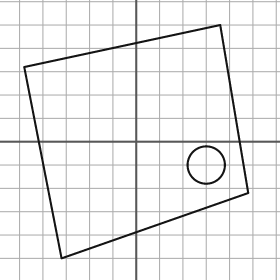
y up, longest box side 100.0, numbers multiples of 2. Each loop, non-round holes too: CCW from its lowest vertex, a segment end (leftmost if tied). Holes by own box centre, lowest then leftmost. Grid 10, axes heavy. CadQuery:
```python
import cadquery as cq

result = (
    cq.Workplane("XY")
    .moveTo(-32.0, -50.0)
    .lineTo(48.0, -22.0)
    .lineTo(36.0, 50.0)
    .lineTo(-48.0, 32.0)
    .close()
    .moveTo(30.0, -10.0)
    .circle(8.0)
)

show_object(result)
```